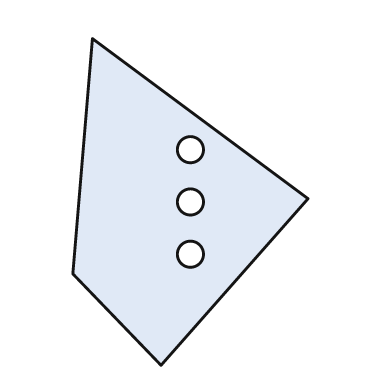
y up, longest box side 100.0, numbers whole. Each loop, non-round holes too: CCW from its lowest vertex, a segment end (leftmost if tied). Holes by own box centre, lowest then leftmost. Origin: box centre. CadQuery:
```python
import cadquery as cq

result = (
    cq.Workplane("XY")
    .moveTo(-9.0, -50.0)
    .lineTo(36.0, 1.0)
    .lineTo(-30.0, 50.0)
    .lineTo(-36.0, -22.0)
    .close()
    .moveTo(0.0, -16.0)
    .circle(4.0)
    .moveTo(0.0, 0.0)
    .circle(4.0)
    .moveTo(0.0, 16.0)
    .circle(4.0)
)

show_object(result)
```